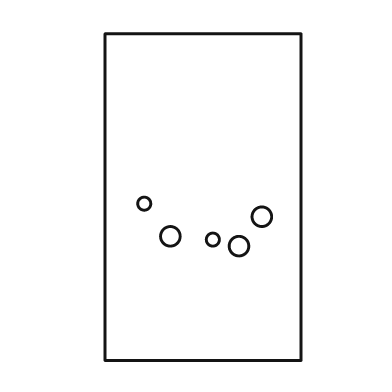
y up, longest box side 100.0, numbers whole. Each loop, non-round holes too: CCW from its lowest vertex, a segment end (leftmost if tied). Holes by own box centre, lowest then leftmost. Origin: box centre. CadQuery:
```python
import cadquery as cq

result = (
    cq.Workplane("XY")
    .moveTo(-30.0, -50.0)
    .lineTo(30.0, -50.0)
    .lineTo(30.0, 50.0)
    .lineTo(-30.0, 50.0)
    .close()
    .moveTo(11.0, -15.0)
    .circle(3.0)
    .moveTo(3.0, -13.0)
    .circle(2.0)
    .moveTo(-10.0, -12.0)
    .circle(3.0)
    .moveTo(18.0, -6.0)
    .circle(3.0)
    .moveTo(-18.0, -2.0)
    .circle(2.0)
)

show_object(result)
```